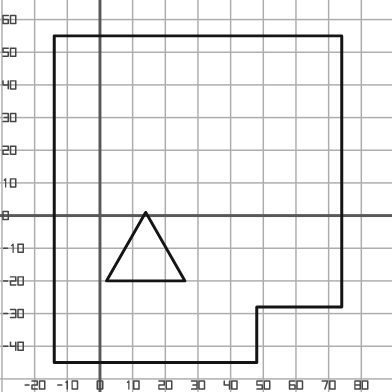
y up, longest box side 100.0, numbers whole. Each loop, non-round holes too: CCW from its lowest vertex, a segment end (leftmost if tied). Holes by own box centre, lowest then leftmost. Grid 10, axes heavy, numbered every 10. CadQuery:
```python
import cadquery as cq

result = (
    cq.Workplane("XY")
    .moveTo(-14.0, -45.0)
    .lineTo(48.0, -45.0)
    .lineTo(48.0, -28.0)
    .lineTo(74.0, -28.0)
    .lineTo(74.0, 55.0)
    .lineTo(-14.0, 55.0)
    .close()
    .moveTo(2.0, -20.0)
    .lineTo(26.0, -20.0)
    .lineTo(14.0, 1.0)
    .close()
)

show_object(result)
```